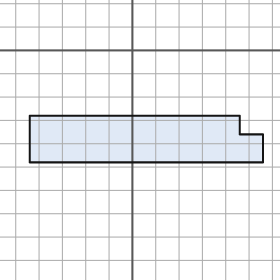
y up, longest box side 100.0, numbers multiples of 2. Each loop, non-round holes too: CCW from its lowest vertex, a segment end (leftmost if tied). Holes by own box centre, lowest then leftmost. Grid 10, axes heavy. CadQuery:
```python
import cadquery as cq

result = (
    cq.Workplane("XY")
    .moveTo(-44.0, -48.0)
    .lineTo(56.0, -48.0)
    .lineTo(56.0, -36.0)
    .lineTo(46.0, -36.0)
    .lineTo(46.0, -28.0)
    .lineTo(-44.0, -28.0)
    .close()
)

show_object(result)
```